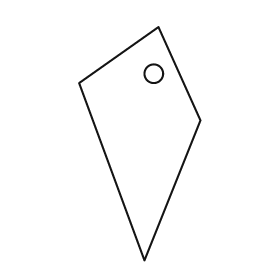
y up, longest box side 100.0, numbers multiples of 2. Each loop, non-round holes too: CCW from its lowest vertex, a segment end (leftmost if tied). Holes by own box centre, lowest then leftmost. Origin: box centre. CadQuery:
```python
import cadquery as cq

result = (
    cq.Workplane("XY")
    .moveTo(2.0, -50.0)
    .lineTo(26.0, 10.0)
    .lineTo(8.0, 50.0)
    .lineTo(-26.0, 26.0)
    .close()
    .moveTo(6.0, 30.0)
    .circle(4.0)
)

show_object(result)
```